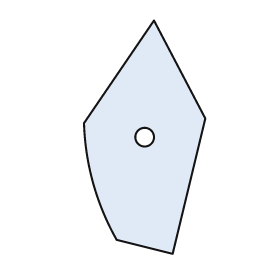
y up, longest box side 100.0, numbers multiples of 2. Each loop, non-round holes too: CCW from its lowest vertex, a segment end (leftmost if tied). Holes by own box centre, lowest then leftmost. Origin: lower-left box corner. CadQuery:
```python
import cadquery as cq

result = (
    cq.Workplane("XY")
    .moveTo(38.0, 0.0)
    .lineTo(52.0, 58.0)
    .lineTo(30.0, 100.0)
    .lineTo(0.0, 56.0)
    .threePointArc((4.0, 30.0), (14.0, 6.0))
    .close()
    .moveTo(26.0, 50.0)
    .circle(4.0)
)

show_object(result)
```